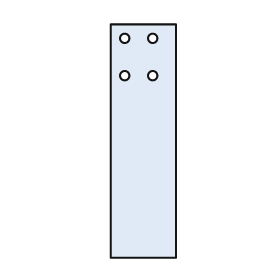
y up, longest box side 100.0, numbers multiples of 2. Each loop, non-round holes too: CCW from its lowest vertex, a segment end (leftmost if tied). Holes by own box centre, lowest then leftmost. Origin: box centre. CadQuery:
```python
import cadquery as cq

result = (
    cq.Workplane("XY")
    .moveTo(-14.0, -50.0)
    .lineTo(14.0, -50.0)
    .lineTo(14.0, 50.0)
    .lineTo(-14.0, 50.0)
    .close()
    .moveTo(-8.0, 28.0)
    .circle(2.0)
    .moveTo(4.0, 28.0)
    .circle(2.0)
    .moveTo(-8.0, 44.0)
    .circle(2.0)
    .moveTo(4.0, 44.0)
    .circle(2.0)
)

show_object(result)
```